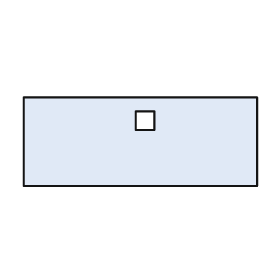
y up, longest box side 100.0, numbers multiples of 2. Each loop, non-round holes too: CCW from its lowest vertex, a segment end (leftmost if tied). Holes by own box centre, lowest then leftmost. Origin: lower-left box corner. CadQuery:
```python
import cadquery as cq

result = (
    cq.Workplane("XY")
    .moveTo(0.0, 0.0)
    .lineTo(100.0, 0.0)
    .lineTo(100.0, 38.0)
    .lineTo(0.0, 38.0)
    .close()
    .moveTo(48.0, 24.0)
    .lineTo(56.0, 24.0)
    .lineTo(56.0, 32.0)
    .lineTo(48.0, 32.0)
    .close()
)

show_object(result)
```